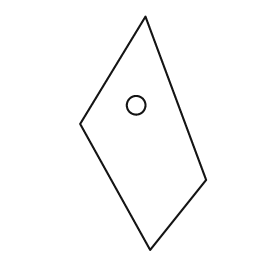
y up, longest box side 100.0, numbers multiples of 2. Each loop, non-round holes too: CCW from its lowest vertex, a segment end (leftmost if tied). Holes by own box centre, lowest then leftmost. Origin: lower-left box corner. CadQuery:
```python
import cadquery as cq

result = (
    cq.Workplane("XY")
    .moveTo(30.0, 0.0)
    .lineTo(54.0, 30.0)
    .lineTo(28.0, 100.0)
    .lineTo(0.0, 54.0)
    .close()
    .moveTo(24.0, 62.0)
    .circle(4.0)
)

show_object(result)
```